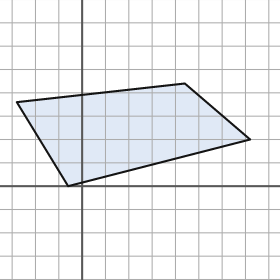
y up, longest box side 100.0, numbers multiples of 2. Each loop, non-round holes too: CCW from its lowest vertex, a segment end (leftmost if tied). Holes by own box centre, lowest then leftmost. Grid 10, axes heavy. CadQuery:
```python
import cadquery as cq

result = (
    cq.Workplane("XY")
    .moveTo(-6.0, 0.0)
    .lineTo(72.0, 20.0)
    .lineTo(44.0, 44.0)
    .lineTo(-28.0, 36.0)
    .close()
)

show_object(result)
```